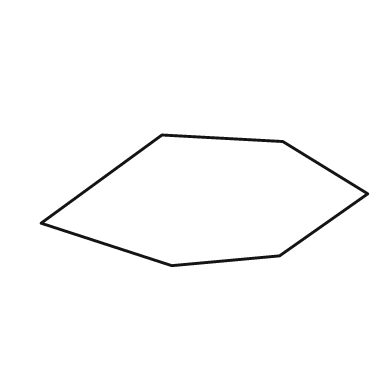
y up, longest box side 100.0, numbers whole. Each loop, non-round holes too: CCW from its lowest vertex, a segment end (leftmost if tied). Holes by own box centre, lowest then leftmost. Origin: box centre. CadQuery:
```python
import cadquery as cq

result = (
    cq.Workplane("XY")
    .moveTo(-10.0, -20.0)
    .lineTo(23.0, -17.0)
    .lineTo(50.0, 2.0)
    .lineTo(24.0, 18.0)
    .lineTo(-13.0, 20.0)
    .lineTo(-50.0, -7.0)
    .close()
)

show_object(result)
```